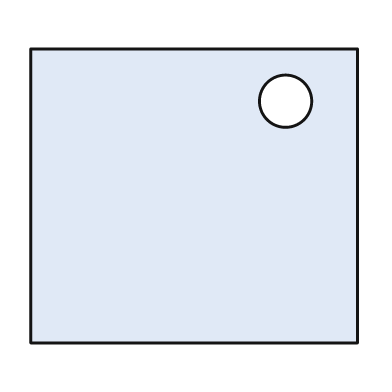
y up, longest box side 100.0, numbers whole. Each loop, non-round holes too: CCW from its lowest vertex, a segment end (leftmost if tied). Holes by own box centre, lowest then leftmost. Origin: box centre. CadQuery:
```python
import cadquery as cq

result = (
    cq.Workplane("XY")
    .moveTo(-50.0, -45.0)
    .lineTo(50.0, -45.0)
    .lineTo(50.0, 45.0)
    .lineTo(-50.0, 45.0)
    .close()
    .moveTo(28.0, 29.0)
    .circle(8.0)
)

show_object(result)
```